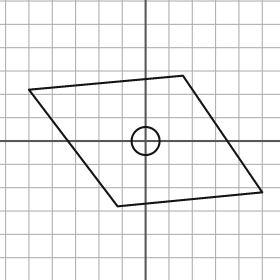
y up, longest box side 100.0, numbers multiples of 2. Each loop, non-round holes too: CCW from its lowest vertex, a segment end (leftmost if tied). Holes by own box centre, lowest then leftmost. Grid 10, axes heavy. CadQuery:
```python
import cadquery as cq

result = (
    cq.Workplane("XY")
    .moveTo(-12.0, -28.0)
    .lineTo(50.0, -22.0)
    .lineTo(16.0, 28.0)
    .lineTo(-50.0, 22.0)
    .close()
    .moveTo(0.0, 0.0)
    .circle(6.0)
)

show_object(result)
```